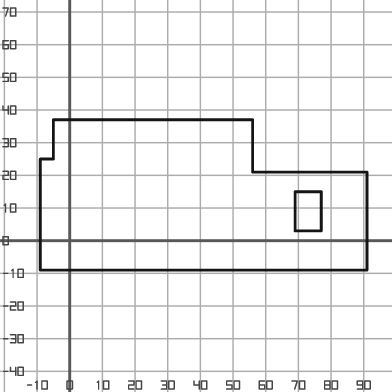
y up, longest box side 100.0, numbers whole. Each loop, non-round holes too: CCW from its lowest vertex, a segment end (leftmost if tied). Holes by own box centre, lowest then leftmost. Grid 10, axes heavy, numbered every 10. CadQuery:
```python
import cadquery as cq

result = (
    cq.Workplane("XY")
    .moveTo(-9.0, -9.0)
    .lineTo(91.0, -9.0)
    .lineTo(91.0, 21.0)
    .lineTo(56.0, 21.0)
    .lineTo(56.0, 37.0)
    .lineTo(-5.0, 37.0)
    .lineTo(-5.0, 25.0)
    .lineTo(-9.0, 25.0)
    .close()
    .moveTo(69.0, 3.0)
    .lineTo(77.0, 3.0)
    .lineTo(77.0, 15.0)
    .lineTo(69.0, 15.0)
    .close()
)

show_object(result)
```